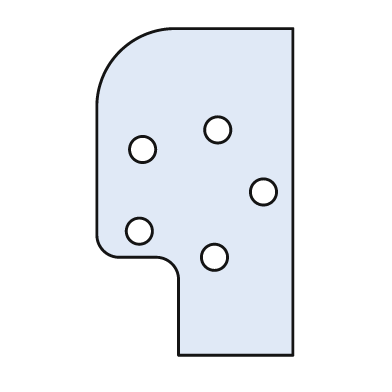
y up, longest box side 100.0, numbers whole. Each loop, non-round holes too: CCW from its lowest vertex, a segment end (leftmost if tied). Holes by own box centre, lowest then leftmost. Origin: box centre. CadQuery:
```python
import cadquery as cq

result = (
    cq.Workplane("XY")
    .moveTo(-5.0, -50.0)
    .lineTo(30.0, -50.0)
    .lineTo(30.0, 50.0)
    .lineTo(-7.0, 50.0)
    .threePointArc((-23.0, 43.0), (-30.0, 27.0))
    .lineTo(-30.0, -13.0)
    .threePointArc((-28.0, -18.0), (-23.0, -20.0))
    .lineTo(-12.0, -20.0)
    .threePointArc((-7.0, -22.0), (-5.0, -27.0))
    .close()
    .moveTo(6.0, -20.0)
    .circle(4.0)
    .moveTo(-17.0, -12.0)
    .circle(4.0)
    .moveTo(21.0, 0.0)
    .circle(4.0)
    .moveTo(-16.0, 13.0)
    .circle(4.0)
    .moveTo(7.0, 19.0)
    .circle(4.0)
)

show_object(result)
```